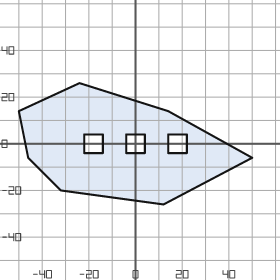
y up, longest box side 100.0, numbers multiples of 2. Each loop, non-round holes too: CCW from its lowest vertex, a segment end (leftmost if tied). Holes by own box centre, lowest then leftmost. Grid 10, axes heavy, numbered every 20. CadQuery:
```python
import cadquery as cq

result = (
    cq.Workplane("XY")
    .moveTo(12.0, -26.0)
    .lineTo(50.0, -6.0)
    .lineTo(14.0, 14.0)
    .lineTo(-24.0, 26.0)
    .lineTo(-50.0, 14.0)
    .lineTo(-46.0, -6.0)
    .lineTo(-32.0, -20.0)
    .close()
    .moveTo(-22.0, -4.0)
    .lineTo(-14.0, -4.0)
    .lineTo(-14.0, 4.0)
    .lineTo(-22.0, 4.0)
    .close()
    .moveTo(-4.0, -4.0)
    .lineTo(4.0, -4.0)
    .lineTo(4.0, 4.0)
    .lineTo(-4.0, 4.0)
    .close()
    .moveTo(14.0, -4.0)
    .lineTo(22.0, -4.0)
    .lineTo(22.0, 4.0)
    .lineTo(14.0, 4.0)
    .close()
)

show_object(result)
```